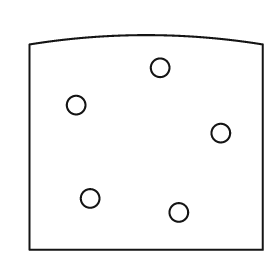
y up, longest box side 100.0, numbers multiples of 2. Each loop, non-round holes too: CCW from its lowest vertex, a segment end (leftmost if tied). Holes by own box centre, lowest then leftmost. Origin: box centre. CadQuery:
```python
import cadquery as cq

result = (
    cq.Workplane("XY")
    .moveTo(-50.0, -46.0)
    .lineTo(50.0, -46.0)
    .lineTo(50.0, 42.0)
    .threePointArc((0.0, 46.0), (-50.0, 42.0))
    .close()
    .moveTo(14.0, -30.0)
    .circle(4.0)
    .moveTo(-24.0, -24.0)
    .circle(4.0)
    .moveTo(32.0, 4.0)
    .circle(4.0)
    .moveTo(-30.0, 16.0)
    .circle(4.0)
    .moveTo(6.0, 32.0)
    .circle(4.0)
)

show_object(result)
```